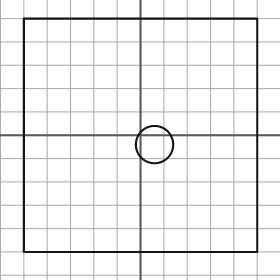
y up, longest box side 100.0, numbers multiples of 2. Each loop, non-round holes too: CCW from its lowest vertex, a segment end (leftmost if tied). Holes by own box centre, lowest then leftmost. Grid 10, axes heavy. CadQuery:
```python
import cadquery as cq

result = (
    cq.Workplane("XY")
    .moveTo(-50.0, -50.0)
    .lineTo(50.0, -50.0)
    .lineTo(50.0, 50.0)
    .lineTo(-50.0, 50.0)
    .close()
    .moveTo(6.0, -4.0)
    .circle(8.0)
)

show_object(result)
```